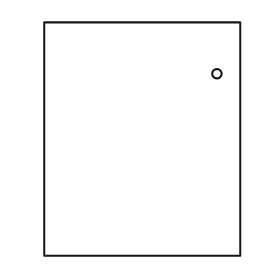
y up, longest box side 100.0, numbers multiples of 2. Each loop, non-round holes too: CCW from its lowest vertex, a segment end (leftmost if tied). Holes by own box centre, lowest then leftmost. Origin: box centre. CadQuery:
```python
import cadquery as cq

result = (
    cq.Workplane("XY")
    .moveTo(-42.0, -50.0)
    .lineTo(42.0, -50.0)
    .lineTo(42.0, 50.0)
    .lineTo(-42.0, 50.0)
    .close()
    .moveTo(32.0, 28.0)
    .circle(2.0)
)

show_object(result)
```